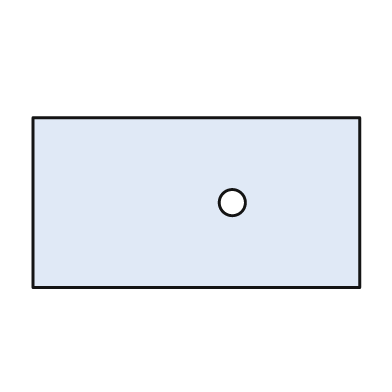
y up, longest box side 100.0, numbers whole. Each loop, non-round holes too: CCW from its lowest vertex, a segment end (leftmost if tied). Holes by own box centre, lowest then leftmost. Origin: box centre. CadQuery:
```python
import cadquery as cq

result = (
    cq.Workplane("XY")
    .moveTo(-50.0, -26.0)
    .lineTo(50.0, -26.0)
    .lineTo(50.0, 26.0)
    .lineTo(-50.0, 26.0)
    .close()
    .moveTo(11.0, 0.0)
    .circle(4.0)
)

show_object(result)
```